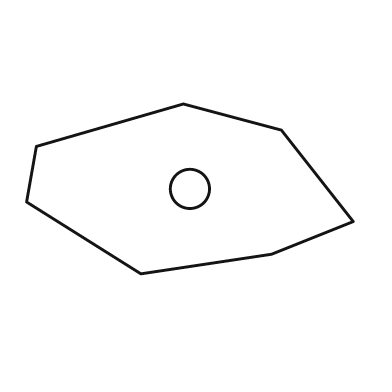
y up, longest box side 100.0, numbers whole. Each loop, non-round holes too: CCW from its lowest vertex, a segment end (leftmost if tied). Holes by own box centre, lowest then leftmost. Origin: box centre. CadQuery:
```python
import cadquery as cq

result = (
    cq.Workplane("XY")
    .moveTo(-15.0, -26.0)
    .lineTo(25.0, -20.0)
    .lineTo(50.0, -10.0)
    .lineTo(28.0, 18.0)
    .lineTo(-2.0, 26.0)
    .lineTo(-47.0, 13.0)
    .lineTo(-50.0, -4.0)
    .close()
    .moveTo(0.0, 0.0)
    .circle(6.0)
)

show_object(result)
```